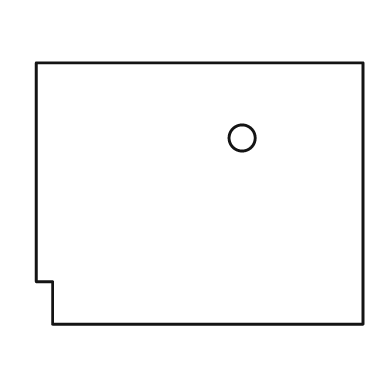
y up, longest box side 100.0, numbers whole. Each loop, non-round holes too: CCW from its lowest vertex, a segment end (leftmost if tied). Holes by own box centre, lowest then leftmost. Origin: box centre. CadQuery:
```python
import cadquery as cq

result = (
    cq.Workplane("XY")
    .moveTo(-45.0, -40.0)
    .lineTo(50.0, -40.0)
    .lineTo(50.0, 40.0)
    .lineTo(-50.0, 40.0)
    .lineTo(-50.0, -27.0)
    .lineTo(-45.0, -27.0)
    .close()
    .moveTo(13.0, 17.0)
    .circle(4.0)
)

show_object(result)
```